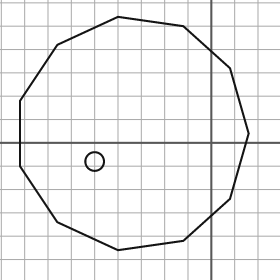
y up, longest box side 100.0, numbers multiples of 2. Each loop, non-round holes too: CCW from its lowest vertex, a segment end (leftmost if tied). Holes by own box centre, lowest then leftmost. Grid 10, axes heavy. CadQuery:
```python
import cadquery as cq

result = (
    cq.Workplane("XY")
    .moveTo(-40.0, -46.0)
    .lineTo(-12.0, -42.0)
    .lineTo(8.0, -24.0)
    .lineTo(16.0, 4.0)
    .lineTo(8.0, 32.0)
    .lineTo(-12.0, 50.0)
    .lineTo(-40.0, 54.0)
    .lineTo(-66.0, 42.0)
    .lineTo(-82.0, 18.0)
    .lineTo(-82.0, -10.0)
    .lineTo(-66.0, -34.0)
    .close()
    .moveTo(-50.0, -8.0)
    .circle(4.0)
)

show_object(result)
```